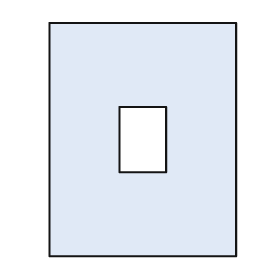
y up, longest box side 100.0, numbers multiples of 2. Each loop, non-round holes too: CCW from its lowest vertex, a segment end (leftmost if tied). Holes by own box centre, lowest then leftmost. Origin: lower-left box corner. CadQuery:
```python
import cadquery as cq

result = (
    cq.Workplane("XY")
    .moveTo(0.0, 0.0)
    .lineTo(80.0, 0.0)
    .lineTo(80.0, 100.0)
    .lineTo(0.0, 100.0)
    .close()
    .moveTo(30.0, 36.0)
    .lineTo(50.0, 36.0)
    .lineTo(50.0, 64.0)
    .lineTo(30.0, 64.0)
    .close()
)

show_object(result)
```